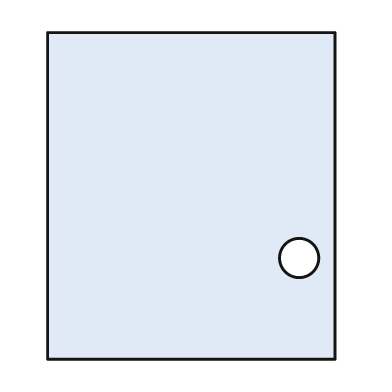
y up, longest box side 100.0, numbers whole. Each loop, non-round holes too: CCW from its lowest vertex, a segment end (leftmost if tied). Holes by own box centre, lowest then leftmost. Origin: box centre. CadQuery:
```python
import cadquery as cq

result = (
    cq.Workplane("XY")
    .moveTo(-44.0, -50.0)
    .lineTo(44.0, -50.0)
    .lineTo(44.0, 50.0)
    .lineTo(-44.0, 50.0)
    .close()
    .moveTo(33.0, -19.0)
    .circle(6.0)
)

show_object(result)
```